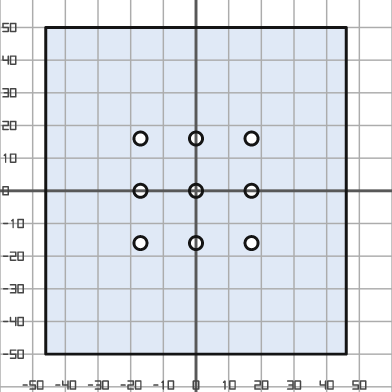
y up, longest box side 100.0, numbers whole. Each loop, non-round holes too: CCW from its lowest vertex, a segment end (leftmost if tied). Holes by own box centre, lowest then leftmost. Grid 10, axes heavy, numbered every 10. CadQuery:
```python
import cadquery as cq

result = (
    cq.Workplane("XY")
    .moveTo(-46.0, -50.0)
    .lineTo(46.0, -50.0)
    .lineTo(46.0, 50.0)
    .lineTo(-46.0, 50.0)
    .close()
    .moveTo(-17.0, -16.0)
    .circle(2.0)
    .moveTo(0.0, -16.0)
    .circle(2.0)
    .moveTo(17.0, -16.0)
    .circle(2.0)
    .moveTo(-17.0, 0.0)
    .circle(2.0)
    .moveTo(0.0, 0.0)
    .circle(2.0)
    .moveTo(17.0, 0.0)
    .circle(2.0)
    .moveTo(-17.0, 16.0)
    .circle(2.0)
    .moveTo(0.0, 16.0)
    .circle(2.0)
    .moveTo(17.0, 16.0)
    .circle(2.0)
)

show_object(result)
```